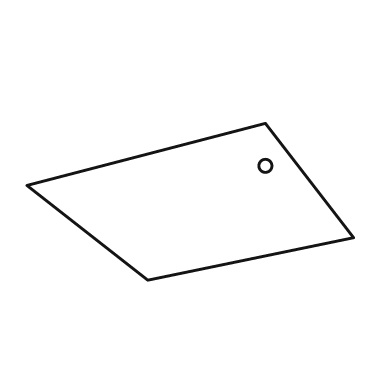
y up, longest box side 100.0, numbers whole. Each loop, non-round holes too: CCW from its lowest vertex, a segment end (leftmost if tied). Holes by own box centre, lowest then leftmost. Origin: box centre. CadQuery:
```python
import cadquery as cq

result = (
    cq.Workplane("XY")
    .moveTo(-13.0, -24.0)
    .lineTo(50.0, -11.0)
    .lineTo(23.0, 24.0)
    .lineTo(-50.0, 5.0)
    .close()
    .moveTo(23.0, 11.0)
    .circle(2.0)
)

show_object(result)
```